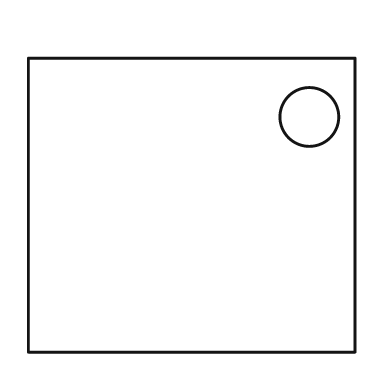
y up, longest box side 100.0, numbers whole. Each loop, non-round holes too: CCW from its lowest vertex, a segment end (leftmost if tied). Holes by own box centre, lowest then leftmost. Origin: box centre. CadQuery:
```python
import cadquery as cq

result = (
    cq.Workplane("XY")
    .moveTo(-50.0, -45.0)
    .lineTo(50.0, -45.0)
    .lineTo(50.0, 45.0)
    .lineTo(-50.0, 45.0)
    .close()
    .moveTo(36.0, 27.0)
    .circle(9.0)
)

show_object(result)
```